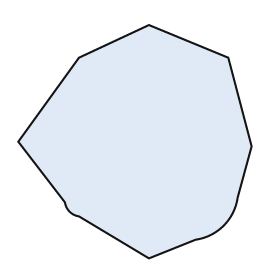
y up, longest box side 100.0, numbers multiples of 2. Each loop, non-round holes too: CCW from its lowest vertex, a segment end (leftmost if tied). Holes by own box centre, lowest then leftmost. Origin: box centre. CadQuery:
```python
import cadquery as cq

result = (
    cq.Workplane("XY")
    .moveTo(6.0, -50.0)
    .lineTo(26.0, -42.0)
    .threePointArc((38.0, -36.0), (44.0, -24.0))
    .lineTo(50.0, -2.0)
    .lineTo(40.0, 36.0)
    .lineTo(6.0, 50.0)
    .lineTo(-24.0, 36.0)
    .lineTo(-50.0, 0.0)
    .lineTo(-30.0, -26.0)
    .threePointArc((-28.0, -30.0), (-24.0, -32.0))
    .close()
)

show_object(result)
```